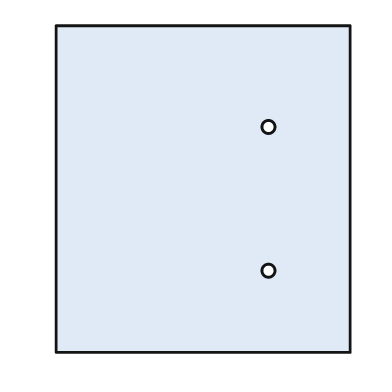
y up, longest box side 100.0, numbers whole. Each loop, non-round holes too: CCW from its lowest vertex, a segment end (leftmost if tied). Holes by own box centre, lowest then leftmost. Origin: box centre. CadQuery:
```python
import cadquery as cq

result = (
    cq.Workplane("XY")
    .moveTo(-45.0, -50.0)
    .lineTo(45.0, -50.0)
    .lineTo(45.0, 50.0)
    .lineTo(-45.0, 50.0)
    .close()
    .moveTo(20.0, -25.0)
    .circle(2.0)
    .moveTo(20.0, 19.0)
    .circle(2.0)
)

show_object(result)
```